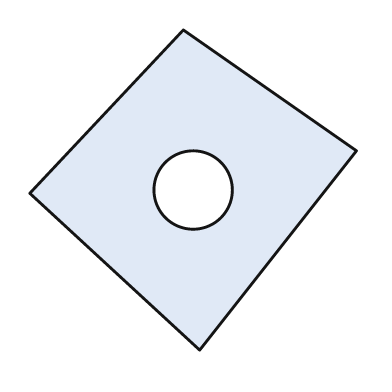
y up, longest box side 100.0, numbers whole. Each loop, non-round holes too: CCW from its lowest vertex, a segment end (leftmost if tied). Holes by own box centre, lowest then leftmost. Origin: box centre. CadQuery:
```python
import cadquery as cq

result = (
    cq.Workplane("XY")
    .moveTo(2.0, -49.0)
    .lineTo(50.0, 12.0)
    .lineTo(-3.0, 49.0)
    .lineTo(-50.0, -1.0)
    .close()
    .moveTo(0.0, 0.0)
    .circle(12.0)
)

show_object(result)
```